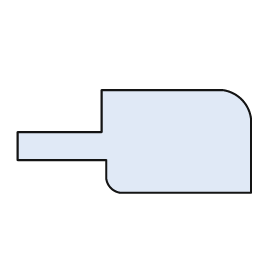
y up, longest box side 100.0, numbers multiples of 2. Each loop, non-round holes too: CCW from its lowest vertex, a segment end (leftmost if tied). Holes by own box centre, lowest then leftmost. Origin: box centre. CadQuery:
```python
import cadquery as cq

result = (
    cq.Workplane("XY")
    .moveTo(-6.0, -22.0)
    .lineTo(50.0, -22.0)
    .lineTo(50.0, 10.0)
    .threePointArc((46.0, 18.0), (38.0, 22.0))
    .lineTo(-14.0, 22.0)
    .lineTo(-14.0, 4.0)
    .lineTo(-50.0, 4.0)
    .lineTo(-50.0, -8.0)
    .lineTo(-12.0, -8.0)
    .lineTo(-12.0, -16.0)
    .threePointArc((-10.0, -20.0), (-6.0, -22.0))
    .close()
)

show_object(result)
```